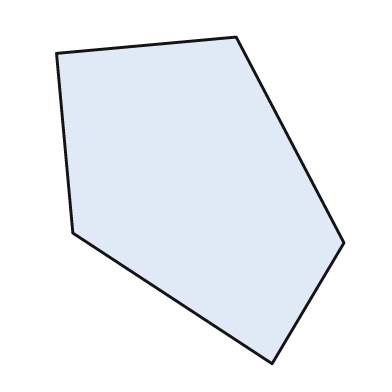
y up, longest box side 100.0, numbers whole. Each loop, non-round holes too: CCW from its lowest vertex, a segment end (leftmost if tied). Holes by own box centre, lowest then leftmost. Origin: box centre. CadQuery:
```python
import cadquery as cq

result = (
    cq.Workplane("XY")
    .moveTo(22.0, -50.0)
    .lineTo(44.0, -13.0)
    .lineTo(11.0, 50.0)
    .lineTo(-44.0, 45.0)
    .lineTo(-39.0, -10.0)
    .close()
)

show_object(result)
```